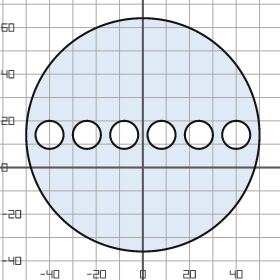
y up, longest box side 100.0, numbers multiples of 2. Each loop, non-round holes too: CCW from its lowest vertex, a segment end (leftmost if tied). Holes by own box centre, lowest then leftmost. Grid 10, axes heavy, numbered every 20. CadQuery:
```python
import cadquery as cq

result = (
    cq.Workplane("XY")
    .moveTo(0.0, 14.0)
    .circle(50.0)
    .moveTo(-40.0, 14.0)
    .circle(6.0)
    .moveTo(-24.0, 14.0)
    .circle(6.0)
    .moveTo(-8.0, 14.0)
    .circle(6.0)
    .moveTo(8.0, 14.0)
    .circle(6.0)
    .moveTo(24.0, 14.0)
    .circle(6.0)
    .moveTo(40.0, 14.0)
    .circle(6.0)
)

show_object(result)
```